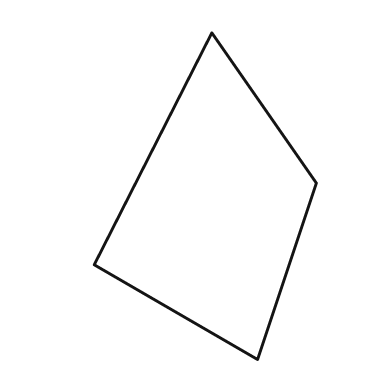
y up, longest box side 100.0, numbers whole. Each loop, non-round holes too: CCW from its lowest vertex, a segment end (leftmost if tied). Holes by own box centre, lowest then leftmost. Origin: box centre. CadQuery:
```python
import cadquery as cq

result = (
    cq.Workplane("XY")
    .moveTo(16.0, -50.0)
    .lineTo(34.0, 4.0)
    .lineTo(2.0, 50.0)
    .lineTo(-34.0, -21.0)
    .close()
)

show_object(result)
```